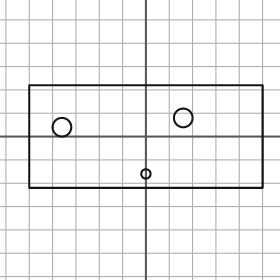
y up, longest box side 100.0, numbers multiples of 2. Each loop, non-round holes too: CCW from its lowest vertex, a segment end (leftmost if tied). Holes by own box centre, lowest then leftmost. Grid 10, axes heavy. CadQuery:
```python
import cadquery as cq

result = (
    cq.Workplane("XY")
    .moveTo(-50.0, -22.0)
    .lineTo(50.0, -22.0)
    .lineTo(50.0, 22.0)
    .lineTo(-50.0, 22.0)
    .close()
    .moveTo(0.0, -16.0)
    .circle(2.0)
    .moveTo(-36.0, 4.0)
    .circle(4.0)
    .moveTo(16.0, 8.0)
    .circle(4.0)
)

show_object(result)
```